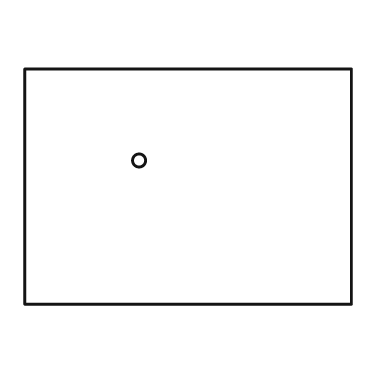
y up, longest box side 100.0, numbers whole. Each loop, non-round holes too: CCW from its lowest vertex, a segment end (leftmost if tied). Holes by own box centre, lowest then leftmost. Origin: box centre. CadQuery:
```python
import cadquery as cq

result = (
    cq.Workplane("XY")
    .moveTo(-50.0, -36.0)
    .lineTo(50.0, -36.0)
    .lineTo(50.0, 36.0)
    .lineTo(-50.0, 36.0)
    .close()
    .moveTo(-15.0, 8.0)
    .circle(2.0)
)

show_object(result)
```